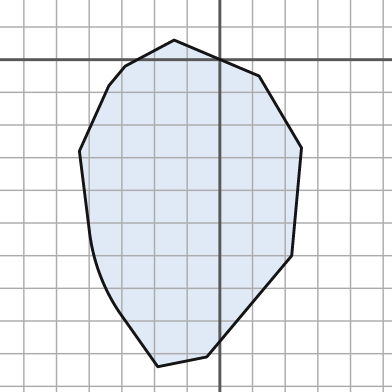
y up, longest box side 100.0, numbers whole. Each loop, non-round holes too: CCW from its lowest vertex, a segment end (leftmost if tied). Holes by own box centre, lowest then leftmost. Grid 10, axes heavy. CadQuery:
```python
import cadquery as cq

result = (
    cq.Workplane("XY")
    .moveTo(-19.0, -94.0)
    .lineTo(-4.0, -91.0)
    .lineTo(22.0, -60.0)
    .lineTo(25.0, -27.0)
    .lineTo(12.0, -5.0)
    .lineTo(-14.0, 6.0)
    .lineTo(-29.0, -2.0)
    .lineTo(-34.0, -8.0)
    .lineTo(-43.0, -28.0)
    .lineTo(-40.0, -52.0)
    .threePointArc((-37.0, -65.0), (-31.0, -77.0))
    .close()
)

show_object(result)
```